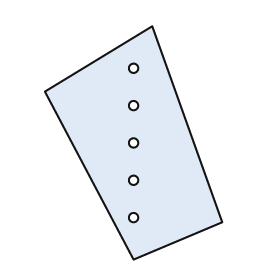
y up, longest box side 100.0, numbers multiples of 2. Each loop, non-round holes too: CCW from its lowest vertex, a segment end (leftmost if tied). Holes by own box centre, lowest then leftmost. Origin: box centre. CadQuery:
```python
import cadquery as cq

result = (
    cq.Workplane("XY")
    .moveTo(0.0, -50.0)
    .lineTo(38.0, -34.0)
    .lineTo(8.0, 50.0)
    .lineTo(-38.0, 22.0)
    .close()
    .moveTo(0.0, -32.0)
    .circle(2.0)
    .moveTo(0.0, -16.0)
    .circle(2.0)
    .moveTo(0.0, 0.0)
    .circle(2.0)
    .moveTo(0.0, 16.0)
    .circle(2.0)
    .moveTo(0.0, 32.0)
    .circle(2.0)
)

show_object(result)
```